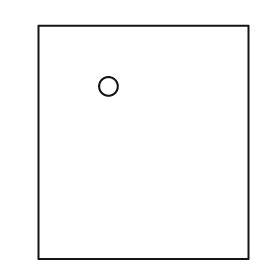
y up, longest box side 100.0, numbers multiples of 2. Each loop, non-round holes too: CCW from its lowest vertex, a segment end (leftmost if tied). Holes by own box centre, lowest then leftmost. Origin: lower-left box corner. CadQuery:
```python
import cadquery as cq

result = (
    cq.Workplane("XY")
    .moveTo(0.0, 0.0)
    .lineTo(90.0, 0.0)
    .lineTo(90.0, 100.0)
    .lineTo(0.0, 100.0)
    .close()
    .moveTo(30.0, 74.0)
    .circle(4.0)
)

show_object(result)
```